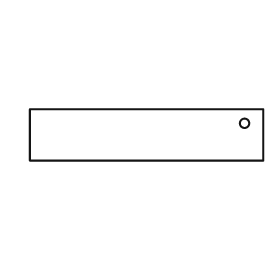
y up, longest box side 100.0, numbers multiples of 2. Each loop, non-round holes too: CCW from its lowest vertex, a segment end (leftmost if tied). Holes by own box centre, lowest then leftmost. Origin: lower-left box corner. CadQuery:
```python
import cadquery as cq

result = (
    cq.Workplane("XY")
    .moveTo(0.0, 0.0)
    .lineTo(100.0, 0.0)
    .lineTo(100.0, 22.0)
    .lineTo(0.0, 22.0)
    .close()
    .moveTo(92.0, 16.0)
    .circle(2.0)
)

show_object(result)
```